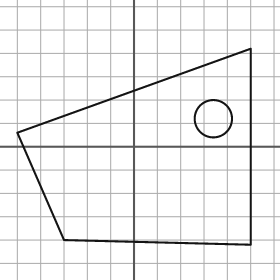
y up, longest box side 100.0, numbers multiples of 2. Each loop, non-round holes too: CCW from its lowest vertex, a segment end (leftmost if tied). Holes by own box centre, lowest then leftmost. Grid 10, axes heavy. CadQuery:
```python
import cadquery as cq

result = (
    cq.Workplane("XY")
    .moveTo(50.0, -42.0)
    .lineTo(50.0, 42.0)
    .lineTo(-50.0, 6.0)
    .lineTo(-30.0, -40.0)
    .close()
    .moveTo(34.0, 12.0)
    .circle(8.0)
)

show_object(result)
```